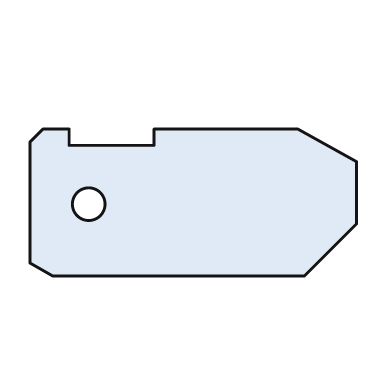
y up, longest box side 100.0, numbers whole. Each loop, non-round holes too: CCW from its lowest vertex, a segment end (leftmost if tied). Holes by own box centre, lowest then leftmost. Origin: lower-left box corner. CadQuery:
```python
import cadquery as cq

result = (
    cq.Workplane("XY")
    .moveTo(7.0, 0.0)
    .lineTo(84.0, 0.0)
    .lineTo(100.0, 16.0)
    .lineTo(100.0, 35.0)
    .lineTo(82.0, 45.0)
    .lineTo(38.0, 45.0)
    .lineTo(38.0, 40.0)
    .lineTo(12.0, 40.0)
    .lineTo(12.0, 45.0)
    .lineTo(4.0, 45.0)
    .lineTo(0.0, 41.0)
    .lineTo(0.0, 4.0)
    .close()
    .moveTo(18.0, 22.0)
    .circle(5.0)
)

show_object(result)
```